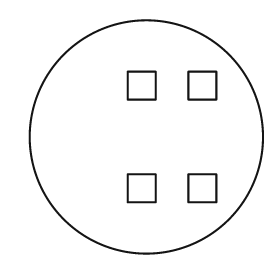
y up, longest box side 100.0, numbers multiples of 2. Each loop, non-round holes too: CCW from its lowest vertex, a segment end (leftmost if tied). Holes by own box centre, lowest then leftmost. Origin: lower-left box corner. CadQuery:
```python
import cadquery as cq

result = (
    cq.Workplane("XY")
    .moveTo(50.0, 50.0)
    .circle(50.0)
    .moveTo(42.0, 22.0)
    .lineTo(54.0, 22.0)
    .lineTo(54.0, 34.0)
    .lineTo(42.0, 34.0)
    .close()
    .moveTo(68.0, 22.0)
    .lineTo(80.0, 22.0)
    .lineTo(80.0, 34.0)
    .lineTo(68.0, 34.0)
    .close()
    .moveTo(42.0, 66.0)
    .lineTo(54.0, 66.0)
    .lineTo(54.0, 78.0)
    .lineTo(42.0, 78.0)
    .close()
    .moveTo(68.0, 66.0)
    .lineTo(80.0, 66.0)
    .lineTo(80.0, 78.0)
    .lineTo(68.0, 78.0)
    .close()
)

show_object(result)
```